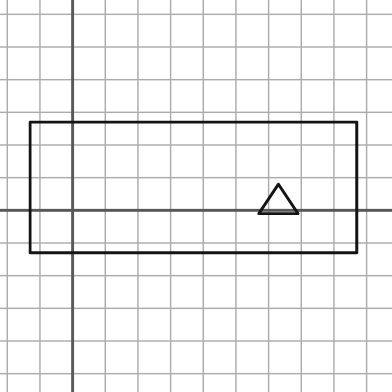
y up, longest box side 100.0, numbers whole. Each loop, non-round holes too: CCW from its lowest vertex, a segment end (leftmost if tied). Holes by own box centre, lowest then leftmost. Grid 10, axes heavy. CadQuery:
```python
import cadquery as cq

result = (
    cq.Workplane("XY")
    .moveTo(-13.0, -13.0)
    .lineTo(87.0, -13.0)
    .lineTo(87.0, 27.0)
    .lineTo(-13.0, 27.0)
    .close()
    .moveTo(57.0, -1.0)
    .lineTo(69.0, -1.0)
    .lineTo(63.0, 8.0)
    .close()
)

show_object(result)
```